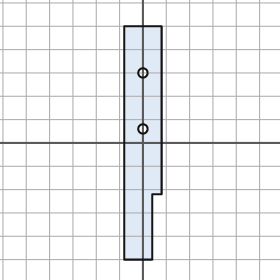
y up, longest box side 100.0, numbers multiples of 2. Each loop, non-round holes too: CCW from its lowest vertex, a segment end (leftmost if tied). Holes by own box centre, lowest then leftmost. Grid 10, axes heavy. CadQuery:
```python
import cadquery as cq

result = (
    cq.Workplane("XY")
    .moveTo(-8.0, -50.0)
    .lineTo(4.0, -50.0)
    .lineTo(4.0, -22.0)
    .lineTo(8.0, -22.0)
    .lineTo(8.0, 50.0)
    .lineTo(-8.0, 50.0)
    .close()
    .moveTo(0.0, 6.0)
    .circle(2.0)
    .moveTo(0.0, 30.0)
    .circle(2.0)
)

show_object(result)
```